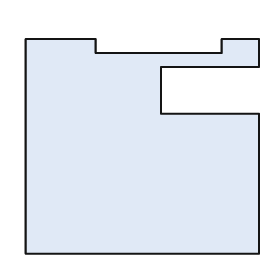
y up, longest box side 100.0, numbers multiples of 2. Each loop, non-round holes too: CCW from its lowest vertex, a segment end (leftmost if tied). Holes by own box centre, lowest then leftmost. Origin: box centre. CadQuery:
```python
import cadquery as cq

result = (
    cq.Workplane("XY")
    .moveTo(-50.0, -46.0)
    .lineTo(50.0, -46.0)
    .lineTo(50.0, 14.0)
    .lineTo(8.0, 14.0)
    .lineTo(8.0, 34.0)
    .lineTo(50.0, 34.0)
    .lineTo(50.0, 46.0)
    .lineTo(34.0, 46.0)
    .lineTo(34.0, 40.0)
    .lineTo(-20.0, 40.0)
    .lineTo(-20.0, 46.0)
    .lineTo(-50.0, 46.0)
    .close()
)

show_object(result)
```